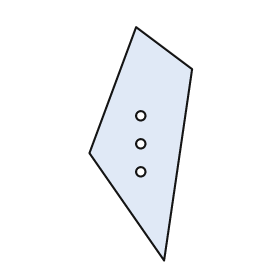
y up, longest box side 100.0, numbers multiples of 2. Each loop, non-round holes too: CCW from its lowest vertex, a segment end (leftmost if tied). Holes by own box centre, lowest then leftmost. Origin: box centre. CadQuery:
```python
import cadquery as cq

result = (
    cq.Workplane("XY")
    .moveTo(10.0, -50.0)
    .lineTo(22.0, 32.0)
    .lineTo(-2.0, 50.0)
    .lineTo(-22.0, -4.0)
    .close()
    .moveTo(0.0, -12.0)
    .circle(2.0)
    .moveTo(0.0, 0.0)
    .circle(2.0)
    .moveTo(0.0, 12.0)
    .circle(2.0)
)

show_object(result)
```